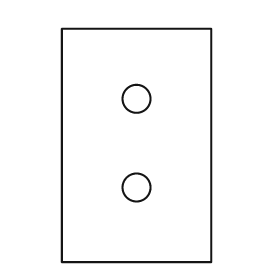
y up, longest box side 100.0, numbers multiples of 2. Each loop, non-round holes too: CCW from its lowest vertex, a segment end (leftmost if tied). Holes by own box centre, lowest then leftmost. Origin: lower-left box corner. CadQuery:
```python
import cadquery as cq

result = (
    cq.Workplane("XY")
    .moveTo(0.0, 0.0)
    .lineTo(64.0, 0.0)
    .lineTo(64.0, 100.0)
    .lineTo(0.0, 100.0)
    .close()
    .moveTo(32.0, 32.0)
    .circle(6.0)
    .moveTo(32.0, 70.0)
    .circle(6.0)
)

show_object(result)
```